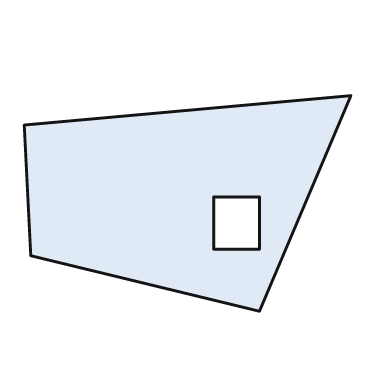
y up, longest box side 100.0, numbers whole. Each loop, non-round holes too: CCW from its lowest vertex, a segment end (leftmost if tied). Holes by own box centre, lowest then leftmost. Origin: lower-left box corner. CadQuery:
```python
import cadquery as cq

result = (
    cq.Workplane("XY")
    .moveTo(72.0, 0.0)
    .lineTo(100.0, 66.0)
    .lineTo(0.0, 57.0)
    .lineTo(2.0, 17.0)
    .close()
    .moveTo(58.0, 19.0)
    .lineTo(72.0, 19.0)
    .lineTo(72.0, 35.0)
    .lineTo(58.0, 35.0)
    .close()
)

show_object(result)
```